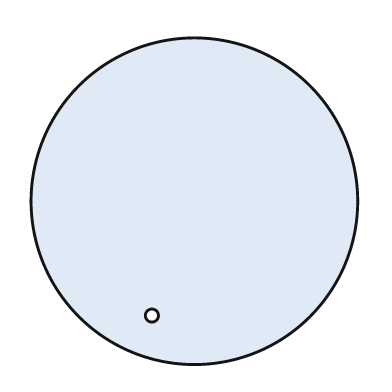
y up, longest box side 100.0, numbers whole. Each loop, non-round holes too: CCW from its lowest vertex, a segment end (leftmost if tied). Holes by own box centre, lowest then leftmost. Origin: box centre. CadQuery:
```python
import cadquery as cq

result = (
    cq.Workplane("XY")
    .moveTo(0.0, 0.0)
    .circle(50.0)
    .moveTo(-13.0, -35.0)
    .circle(2.0)
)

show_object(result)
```